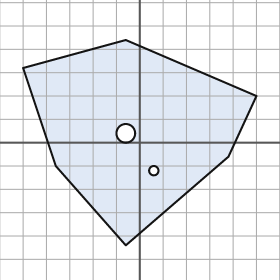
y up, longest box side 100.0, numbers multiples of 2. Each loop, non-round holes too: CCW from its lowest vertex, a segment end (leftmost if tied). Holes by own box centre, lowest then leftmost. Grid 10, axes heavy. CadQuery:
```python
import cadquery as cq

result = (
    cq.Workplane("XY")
    .moveTo(-6.0, -44.0)
    .lineTo(38.0, -6.0)
    .lineTo(50.0, 20.0)
    .lineTo(-6.0, 44.0)
    .lineTo(-50.0, 32.0)
    .lineTo(-36.0, -10.0)
    .close()
    .moveTo(6.0, -12.0)
    .circle(2.0)
    .moveTo(-6.0, 4.0)
    .circle(4.0)
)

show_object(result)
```